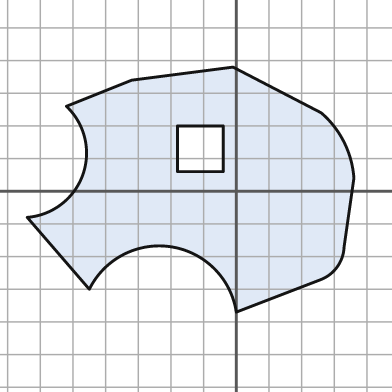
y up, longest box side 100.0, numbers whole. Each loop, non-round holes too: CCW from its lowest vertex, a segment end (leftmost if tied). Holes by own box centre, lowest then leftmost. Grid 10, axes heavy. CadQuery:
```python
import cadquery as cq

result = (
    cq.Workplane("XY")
    .moveTo(0.0, -37.0)
    .lineTo(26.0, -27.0)
    .threePointArc((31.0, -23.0), (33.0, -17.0))
    .lineTo(36.0, 4.0)
    .threePointArc((33.0, 15.0), (26.0, 24.0))
    .lineTo(-1.0, 38.0)
    .lineTo(-32.0, 34.0)
    .lineTo(-52.0, 26.0)
    .threePointArc((-47.0, 5.0), (-64.0, -8.0))
    .lineTo(-45.0, -30.0)
    .threePointArc((-20.0, -17.0), (0.0, -37.0))
    .close()
    .moveTo(-18.0, 6.0)
    .lineTo(-4.0, 6.0)
    .lineTo(-4.0, 20.0)
    .lineTo(-18.0, 20.0)
    .close()
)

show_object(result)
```